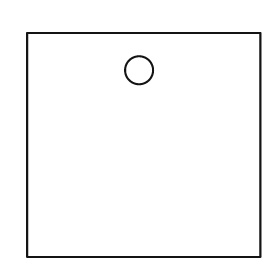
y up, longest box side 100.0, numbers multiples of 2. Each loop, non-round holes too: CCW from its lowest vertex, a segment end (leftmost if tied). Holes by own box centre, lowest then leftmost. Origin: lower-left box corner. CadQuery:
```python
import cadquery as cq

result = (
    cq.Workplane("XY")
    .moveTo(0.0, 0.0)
    .lineTo(100.0, 0.0)
    .lineTo(100.0, 96.0)
    .lineTo(0.0, 96.0)
    .close()
    .moveTo(48.0, 80.0)
    .circle(6.0)
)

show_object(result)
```